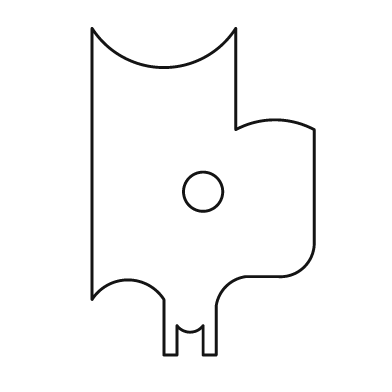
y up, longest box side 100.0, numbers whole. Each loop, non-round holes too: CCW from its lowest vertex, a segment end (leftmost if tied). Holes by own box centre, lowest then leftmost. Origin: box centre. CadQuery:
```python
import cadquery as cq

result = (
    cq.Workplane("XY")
    .moveTo(-12.0, -50.0)
    .lineTo(-8.0, -50.0)
    .lineTo(-8.0, -41.0)
    .threePointArc((-4.0, -43.0), (0.0, -41.0))
    .lineTo(0.0, -50.0)
    .lineTo(4.0, -50.0)
    .lineTo(4.0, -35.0)
    .threePointArc((7.0, -29.0), (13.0, -26.0))
    .lineTo(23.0, -26.0)
    .threePointArc((31.0, -23.0), (34.0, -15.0))
    .lineTo(34.0, 19.0)
    .threePointArc((22.0, 22.0), (10.0, 19.0))
    .lineTo(10.0, 50.0)
    .threePointArc((-12.0, 38.0), (-34.0, 50.0))
    .lineTo(-34.0, -33.0)
    .threePointArc((-23.0, -27.0), (-12.0, -33.0))
    .close()
    .moveTo(0.0, 0.0)
    .circle(6.0)
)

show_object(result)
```